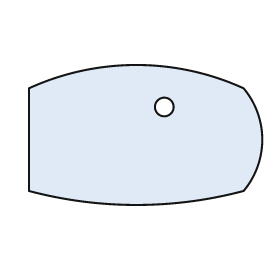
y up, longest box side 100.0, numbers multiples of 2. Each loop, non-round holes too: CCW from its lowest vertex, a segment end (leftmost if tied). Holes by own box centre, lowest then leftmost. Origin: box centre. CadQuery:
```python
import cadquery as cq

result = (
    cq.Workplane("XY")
    .moveTo(-50.0, -24.0)
    .threePointArc((-4.0, -30.0), (42.0, -24.0))
    .threePointArc((50.0, -2.0), (42.0, 20.0))
    .threePointArc((-4.0, 30.0), (-50.0, 20.0))
    .close()
    .moveTo(8.0, 12.0)
    .circle(4.0)
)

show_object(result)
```